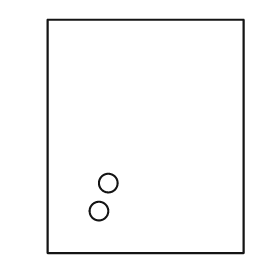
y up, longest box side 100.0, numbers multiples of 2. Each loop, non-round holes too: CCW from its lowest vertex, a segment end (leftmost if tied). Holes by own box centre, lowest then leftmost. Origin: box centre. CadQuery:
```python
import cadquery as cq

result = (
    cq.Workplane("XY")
    .moveTo(-42.0, -50.0)
    .lineTo(42.0, -50.0)
    .lineTo(42.0, 50.0)
    .lineTo(-42.0, 50.0)
    .close()
    .moveTo(-20.0, -32.0)
    .circle(4.0)
    .moveTo(-16.0, -20.0)
    .circle(4.0)
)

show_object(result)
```